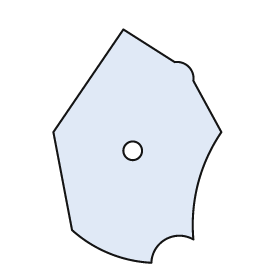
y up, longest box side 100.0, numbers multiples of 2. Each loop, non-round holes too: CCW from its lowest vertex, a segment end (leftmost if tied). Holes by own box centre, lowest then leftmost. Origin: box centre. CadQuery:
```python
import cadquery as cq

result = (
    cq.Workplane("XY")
    .moveTo(6.0, -50.0)
    .threePointArc((12.0, -40.0), (24.0, -40.0))
    .threePointArc((26.0, -16.0), (36.0, 6.0))
    .lineTo(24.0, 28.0)
    .threePointArc((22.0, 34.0), (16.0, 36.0))
    .lineTo(-6.0, 50.0)
    .lineTo(-36.0, 6.0)
    .lineTo(-28.0, -36.0)
    .threePointArc((-12.0, -46.0), (6.0, -50.0))
    .close()
    .moveTo(-2.0, -2.0)
    .circle(4.0)
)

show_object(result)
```